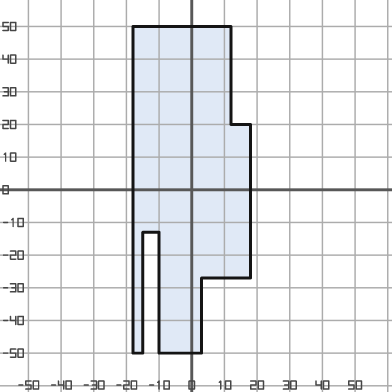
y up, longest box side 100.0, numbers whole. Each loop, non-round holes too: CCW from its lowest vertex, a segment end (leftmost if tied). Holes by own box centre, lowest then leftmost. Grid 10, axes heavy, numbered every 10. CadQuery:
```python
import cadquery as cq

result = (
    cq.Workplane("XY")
    .moveTo(-18.0, -50.0)
    .lineTo(-15.0, -50.0)
    .lineTo(-15.0, -13.0)
    .lineTo(-10.0, -13.0)
    .lineTo(-10.0, -50.0)
    .lineTo(3.0, -50.0)
    .lineTo(3.0, -27.0)
    .lineTo(18.0, -27.0)
    .lineTo(18.0, 20.0)
    .lineTo(12.0, 20.0)
    .lineTo(12.0, 50.0)
    .lineTo(-18.0, 50.0)
    .close()
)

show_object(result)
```